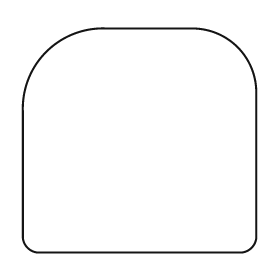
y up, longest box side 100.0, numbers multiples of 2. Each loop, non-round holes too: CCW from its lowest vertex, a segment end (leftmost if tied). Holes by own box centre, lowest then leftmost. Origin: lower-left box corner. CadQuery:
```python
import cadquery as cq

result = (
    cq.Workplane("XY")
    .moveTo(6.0, 0.0)
    .lineTo(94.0, 0.0)
    .threePointArc((98.0, 2.0), (100.0, 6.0))
    .lineTo(100.0, 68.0)
    .threePointArc((92.0, 88.0), (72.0, 96.0))
    .lineTo(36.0, 96.0)
    .threePointArc((10.0, 86.0), (0.0, 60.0))
    .lineTo(0.0, 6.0)
    .threePointArc((2.0, 2.0), (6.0, 0.0))
    .close()
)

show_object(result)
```